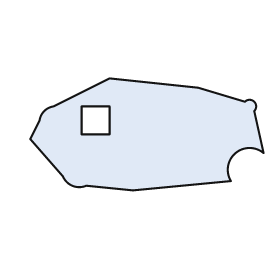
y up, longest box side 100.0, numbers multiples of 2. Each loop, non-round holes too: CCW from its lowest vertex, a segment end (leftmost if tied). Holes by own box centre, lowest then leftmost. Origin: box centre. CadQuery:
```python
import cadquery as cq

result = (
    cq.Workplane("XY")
    .moveTo(-6.0, -24.0)
    .lineTo(36.0, -20.0)
    .threePointArc((38.0, -8.0), (50.0, -8.0))
    .lineTo(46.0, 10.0)
    .threePointArc((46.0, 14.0), (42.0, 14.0))
    .lineTo(22.0, 20.0)
    .lineTo(-16.0, 24.0)
    .lineTo(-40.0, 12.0)
    .threePointArc((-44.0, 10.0), (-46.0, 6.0))
    .lineTo(-50.0, -2.0)
    .lineTo(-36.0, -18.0)
    .threePointArc((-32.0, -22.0), (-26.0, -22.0))
    .close()
    .moveTo(-28.0, 0.0)
    .lineTo(-16.0, 0.0)
    .lineTo(-16.0, 12.0)
    .lineTo(-28.0, 12.0)
    .close()
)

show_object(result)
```